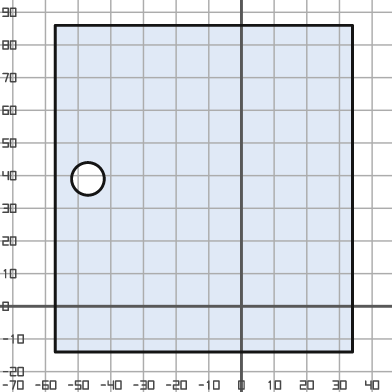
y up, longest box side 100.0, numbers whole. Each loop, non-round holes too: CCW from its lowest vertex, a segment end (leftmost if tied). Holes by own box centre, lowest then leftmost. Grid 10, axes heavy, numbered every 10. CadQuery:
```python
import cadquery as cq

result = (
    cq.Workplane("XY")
    .moveTo(-57.0, -14.0)
    .lineTo(34.0, -14.0)
    .lineTo(34.0, 86.0)
    .lineTo(-57.0, 86.0)
    .close()
    .moveTo(-47.0, 39.0)
    .circle(5.0)
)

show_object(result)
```